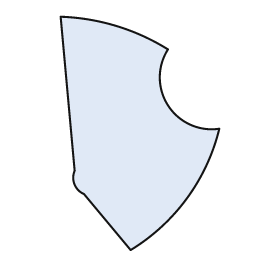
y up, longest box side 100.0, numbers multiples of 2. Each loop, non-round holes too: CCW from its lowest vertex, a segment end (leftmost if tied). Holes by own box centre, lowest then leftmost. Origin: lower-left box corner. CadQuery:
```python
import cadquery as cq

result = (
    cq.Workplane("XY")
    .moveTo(30.0, 0.0)
    .threePointArc((54.0, 22.0), (68.0, 52.0))
    .threePointArc((46.0, 62.0), (46.0, 86.0))
    .threePointArc((24.0, 96.0), (0.0, 100.0))
    .lineTo(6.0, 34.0)
    .threePointArc((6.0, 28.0), (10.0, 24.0))
    .close()
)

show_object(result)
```